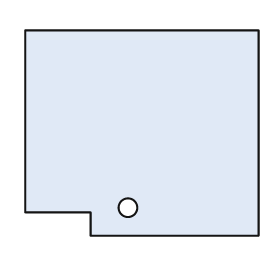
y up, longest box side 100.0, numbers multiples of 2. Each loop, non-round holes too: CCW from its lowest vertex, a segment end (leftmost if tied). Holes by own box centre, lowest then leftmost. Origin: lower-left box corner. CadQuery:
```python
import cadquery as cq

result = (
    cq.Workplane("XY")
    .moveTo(28.0, 0.0)
    .lineTo(100.0, 0.0)
    .lineTo(100.0, 88.0)
    .lineTo(0.0, 88.0)
    .lineTo(0.0, 10.0)
    .lineTo(28.0, 10.0)
    .close()
    .moveTo(44.0, 12.0)
    .circle(4.0)
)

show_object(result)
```